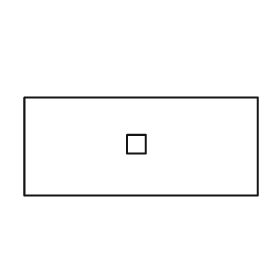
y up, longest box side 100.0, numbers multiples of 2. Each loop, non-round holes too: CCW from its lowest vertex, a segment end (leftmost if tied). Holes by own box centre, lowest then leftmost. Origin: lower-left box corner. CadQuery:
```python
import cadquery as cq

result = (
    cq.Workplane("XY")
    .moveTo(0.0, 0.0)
    .lineTo(100.0, 0.0)
    .lineTo(100.0, 42.0)
    .lineTo(0.0, 42.0)
    .close()
    .moveTo(44.0, 18.0)
    .lineTo(52.0, 18.0)
    .lineTo(52.0, 26.0)
    .lineTo(44.0, 26.0)
    .close()
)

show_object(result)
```